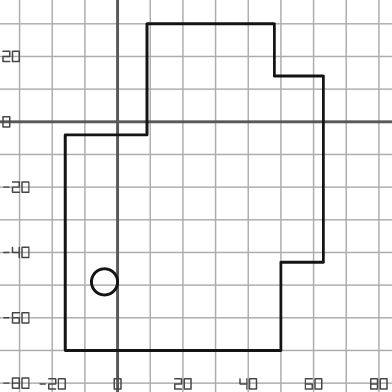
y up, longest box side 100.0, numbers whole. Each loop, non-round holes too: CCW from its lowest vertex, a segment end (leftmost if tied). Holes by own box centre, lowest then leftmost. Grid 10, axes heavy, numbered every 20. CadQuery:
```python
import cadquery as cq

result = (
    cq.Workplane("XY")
    .moveTo(-16.0, -70.0)
    .lineTo(50.0, -70.0)
    .lineTo(50.0, -43.0)
    .lineTo(63.0, -43.0)
    .lineTo(63.0, 14.0)
    .lineTo(48.0, 14.0)
    .lineTo(48.0, 30.0)
    .lineTo(9.0, 30.0)
    .lineTo(9.0, -4.0)
    .lineTo(-16.0, -4.0)
    .close()
    .moveTo(-4.0, -49.0)
    .circle(4.0)
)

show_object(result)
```